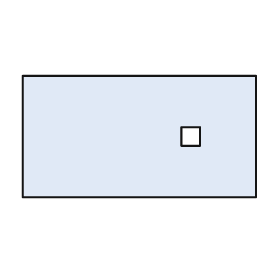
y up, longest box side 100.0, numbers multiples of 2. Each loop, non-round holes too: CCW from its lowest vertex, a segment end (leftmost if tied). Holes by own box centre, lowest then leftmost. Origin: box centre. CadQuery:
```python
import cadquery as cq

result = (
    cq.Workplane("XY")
    .moveTo(-50.0, -26.0)
    .lineTo(50.0, -26.0)
    .lineTo(50.0, 26.0)
    .lineTo(-50.0, 26.0)
    .close()
    .moveTo(18.0, -4.0)
    .lineTo(26.0, -4.0)
    .lineTo(26.0, 4.0)
    .lineTo(18.0, 4.0)
    .close()
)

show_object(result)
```